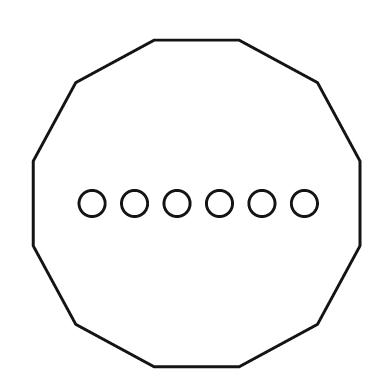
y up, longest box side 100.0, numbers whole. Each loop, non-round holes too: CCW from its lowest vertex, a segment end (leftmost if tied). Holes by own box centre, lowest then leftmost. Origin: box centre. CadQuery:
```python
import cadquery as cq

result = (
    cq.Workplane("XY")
    .moveTo(-13.0, -50.0)
    .lineTo(13.0, -50.0)
    .lineTo(37.0, -37.0)
    .lineTo(50.0, -13.0)
    .lineTo(50.0, 13.0)
    .lineTo(37.0, 37.0)
    .lineTo(13.0, 50.0)
    .lineTo(-13.0, 50.0)
    .lineTo(-37.0, 37.0)
    .lineTo(-50.0, 13.0)
    .lineTo(-50.0, -13.0)
    .lineTo(-37.0, -37.0)
    .close()
    .moveTo(-32.0, 0.0)
    .circle(4.0)
    .moveTo(-19.0, 0.0)
    .circle(4.0)
    .moveTo(-6.0, 0.0)
    .circle(4.0)
    .moveTo(7.0, 0.0)
    .circle(4.0)
    .moveTo(20.0, 0.0)
    .circle(4.0)
    .moveTo(33.0, 0.0)
    .circle(4.0)
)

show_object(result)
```